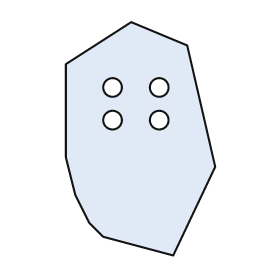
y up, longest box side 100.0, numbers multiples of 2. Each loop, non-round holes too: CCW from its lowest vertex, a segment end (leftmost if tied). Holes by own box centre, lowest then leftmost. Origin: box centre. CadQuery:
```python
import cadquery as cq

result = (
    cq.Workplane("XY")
    .moveTo(14.0, -50.0)
    .lineTo(32.0, -12.0)
    .lineTo(20.0, 40.0)
    .lineTo(-4.0, 50.0)
    .lineTo(-32.0, 32.0)
    .lineTo(-32.0, -8.0)
    .lineTo(-28.0, -24.0)
    .lineTo(-22.0, -36.0)
    .lineTo(-16.0, -42.0)
    .close()
    .moveTo(-12.0, 8.0)
    .circle(4.0)
    .moveTo(8.0, 8.0)
    .circle(4.0)
    .moveTo(-12.0, 22.0)
    .circle(4.0)
    .moveTo(8.0, 22.0)
    .circle(4.0)
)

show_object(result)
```